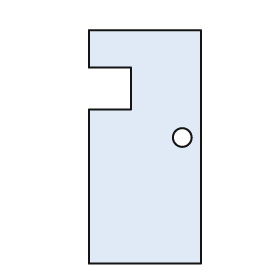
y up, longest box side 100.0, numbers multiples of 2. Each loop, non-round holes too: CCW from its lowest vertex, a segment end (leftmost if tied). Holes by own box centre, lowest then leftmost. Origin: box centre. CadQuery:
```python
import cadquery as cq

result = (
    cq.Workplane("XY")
    .moveTo(-24.0, -50.0)
    .lineTo(24.0, -50.0)
    .lineTo(24.0, 50.0)
    .lineTo(-24.0, 50.0)
    .lineTo(-24.0, 34.0)
    .lineTo(-6.0, 34.0)
    .lineTo(-6.0, 16.0)
    .lineTo(-24.0, 16.0)
    .close()
    .moveTo(16.0, 4.0)
    .circle(4.0)
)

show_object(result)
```